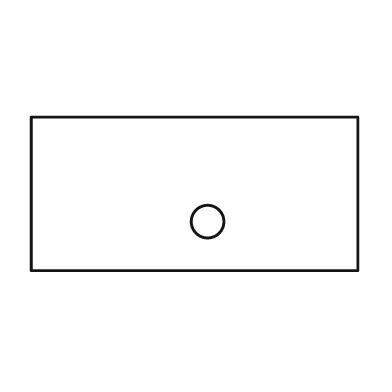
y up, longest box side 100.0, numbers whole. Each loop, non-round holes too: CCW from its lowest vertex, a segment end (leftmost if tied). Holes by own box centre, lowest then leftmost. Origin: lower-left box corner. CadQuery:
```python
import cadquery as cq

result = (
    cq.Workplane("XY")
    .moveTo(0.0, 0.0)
    .lineTo(100.0, 0.0)
    .lineTo(100.0, 47.0)
    .lineTo(0.0, 47.0)
    .close()
    .moveTo(54.0, 15.0)
    .circle(5.0)
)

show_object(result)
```